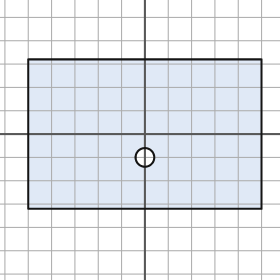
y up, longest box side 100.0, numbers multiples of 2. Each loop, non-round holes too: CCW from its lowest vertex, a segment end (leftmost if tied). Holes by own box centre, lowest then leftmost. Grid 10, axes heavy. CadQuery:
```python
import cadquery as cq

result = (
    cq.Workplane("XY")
    .moveTo(-50.0, -32.0)
    .lineTo(50.0, -32.0)
    .lineTo(50.0, 32.0)
    .lineTo(-50.0, 32.0)
    .close()
    .moveTo(0.0, -10.0)
    .circle(4.0)
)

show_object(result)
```